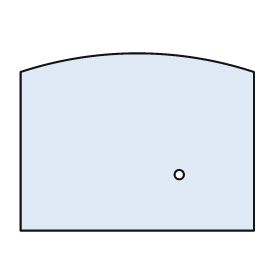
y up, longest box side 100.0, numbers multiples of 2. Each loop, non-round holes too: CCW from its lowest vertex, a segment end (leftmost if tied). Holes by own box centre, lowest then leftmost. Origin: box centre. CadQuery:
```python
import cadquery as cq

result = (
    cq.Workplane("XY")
    .moveTo(-50.0, -38.0)
    .lineTo(50.0, -38.0)
    .lineTo(50.0, 30.0)
    .threePointArc((0.0, 38.0), (-50.0, 30.0))
    .close()
    .moveTo(18.0, -14.0)
    .circle(2.0)
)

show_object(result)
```